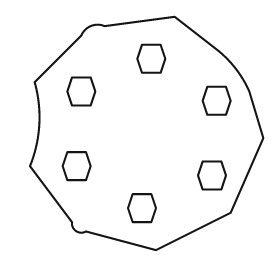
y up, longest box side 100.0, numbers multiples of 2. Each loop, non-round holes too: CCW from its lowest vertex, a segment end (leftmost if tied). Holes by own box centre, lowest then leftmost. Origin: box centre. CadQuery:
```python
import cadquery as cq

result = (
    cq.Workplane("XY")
    .moveTo(4.0, -50.0)
    .lineTo(36.0, -34.0)
    .lineTo(50.0, -2.0)
    .lineTo(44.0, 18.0)
    .threePointArc((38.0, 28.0), (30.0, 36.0))
    .lineTo(12.0, 50.0)
    .lineTo(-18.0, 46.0)
    .threePointArc((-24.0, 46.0), (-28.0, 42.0))
    .lineTo(-48.0, 22.0)
    .threePointArc((-46.0, 4.0), (-50.0, -14.0))
    .lineTo(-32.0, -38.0)
    .threePointArc((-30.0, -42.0), (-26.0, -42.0))
    .close()
    .moveTo(-6.0, -38.0)
    .lineTo(2.0, -38.0)
    .lineTo(4.0, -32.0)
    .lineTo(2.0, -26.0)
    .lineTo(-6.0, -26.0)
    .lineTo(-8.0, -32.0)
    .close()
    .moveTo(24.0, -24.0)
    .lineTo(32.0, -24.0)
    .lineTo(34.0, -18.0)
    .lineTo(32.0, -12.0)
    .lineTo(24.0, -12.0)
    .lineTo(22.0, -18.0)
    .close()
    .moveTo(-34.0, -20.0)
    .lineTo(-26.0, -20.0)
    .lineTo(-24.0, -14.0)
    .lineTo(-26.0, -8.0)
    .lineTo(-34.0, -8.0)
    .lineTo(-36.0, -14.0)
    .close()
    .moveTo(26.0, 8.0)
    .lineTo(34.0, 8.0)
    .lineTo(36.0, 14.0)
    .lineTo(34.0, 20.0)
    .lineTo(26.0, 20.0)
    .lineTo(24.0, 14.0)
    .close()
    .moveTo(-32.0, 12.0)
    .lineTo(-24.0, 12.0)
    .lineTo(-22.0, 18.0)
    .lineTo(-24.0, 24.0)
    .lineTo(-32.0, 24.0)
    .lineTo(-34.0, 18.0)
    .close()
    .moveTo(-2.0, 26.0)
    .lineTo(6.0, 26.0)
    .lineTo(8.0, 32.0)
    .lineTo(6.0, 38.0)
    .lineTo(-2.0, 38.0)
    .lineTo(-4.0, 32.0)
    .close()
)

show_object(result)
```